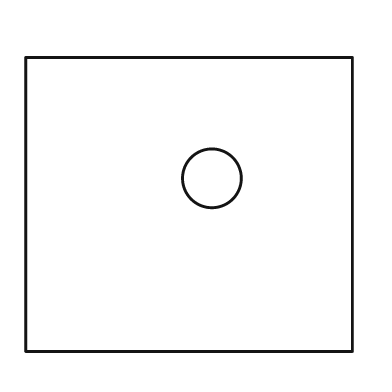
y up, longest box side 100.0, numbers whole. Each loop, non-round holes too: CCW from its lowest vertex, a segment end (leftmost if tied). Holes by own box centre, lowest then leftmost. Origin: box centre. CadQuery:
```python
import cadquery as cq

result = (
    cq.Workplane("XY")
    .moveTo(-50.0, -45.0)
    .lineTo(50.0, -45.0)
    .lineTo(50.0, 45.0)
    .lineTo(-50.0, 45.0)
    .close()
    .moveTo(7.0, 8.0)
    .circle(9.0)
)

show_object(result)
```